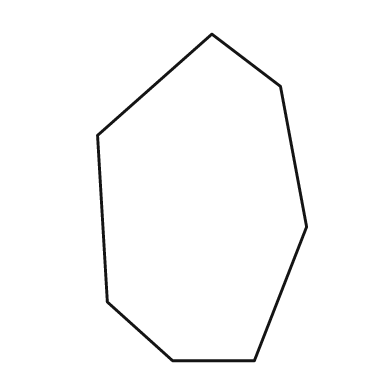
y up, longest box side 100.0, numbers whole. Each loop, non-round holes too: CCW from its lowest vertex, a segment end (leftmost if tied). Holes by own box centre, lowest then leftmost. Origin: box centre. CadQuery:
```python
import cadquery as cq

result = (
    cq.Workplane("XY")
    .moveTo(-9.0, -50.0)
    .lineTo(16.0, -50.0)
    .lineTo(32.0, -9.0)
    .lineTo(24.0, 34.0)
    .lineTo(3.0, 50.0)
    .lineTo(-32.0, 19.0)
    .lineTo(-29.0, -32.0)
    .close()
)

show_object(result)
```